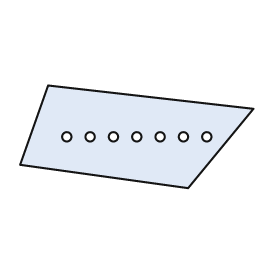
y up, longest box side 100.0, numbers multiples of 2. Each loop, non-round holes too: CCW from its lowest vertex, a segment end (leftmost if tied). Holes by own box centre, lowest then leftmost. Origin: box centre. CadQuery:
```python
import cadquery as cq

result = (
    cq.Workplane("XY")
    .moveTo(22.0, -22.0)
    .lineTo(50.0, 12.0)
    .lineTo(-38.0, 22.0)
    .lineTo(-50.0, -12.0)
    .close()
    .moveTo(-30.0, 0.0)
    .circle(2.0)
    .moveTo(-20.0, 0.0)
    .circle(2.0)
    .moveTo(-10.0, 0.0)
    .circle(2.0)
    .moveTo(0.0, 0.0)
    .circle(2.0)
    .moveTo(10.0, 0.0)
    .circle(2.0)
    .moveTo(20.0, 0.0)
    .circle(2.0)
    .moveTo(30.0, 0.0)
    .circle(2.0)
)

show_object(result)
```